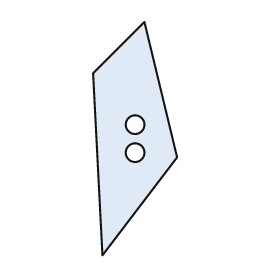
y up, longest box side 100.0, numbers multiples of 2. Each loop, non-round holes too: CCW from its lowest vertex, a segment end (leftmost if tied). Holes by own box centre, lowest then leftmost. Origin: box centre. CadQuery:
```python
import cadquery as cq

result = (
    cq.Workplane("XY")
    .moveTo(-14.0, -50.0)
    .lineTo(18.0, -8.0)
    .lineTo(4.0, 50.0)
    .lineTo(-18.0, 28.0)
    .close()
    .moveTo(0.0, -6.0)
    .circle(4.0)
    .moveTo(0.0, 6.0)
    .circle(4.0)
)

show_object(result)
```